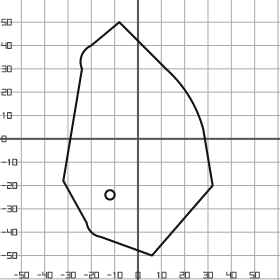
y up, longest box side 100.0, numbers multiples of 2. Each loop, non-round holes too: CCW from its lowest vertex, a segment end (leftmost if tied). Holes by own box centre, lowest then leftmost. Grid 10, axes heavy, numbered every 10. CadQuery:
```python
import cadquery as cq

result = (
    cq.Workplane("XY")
    .moveTo(6.0, -50.0)
    .lineTo(32.0, -20.0)
    .lineTo(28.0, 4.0)
    .threePointArc((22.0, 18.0), (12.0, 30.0))
    .lineTo(-8.0, 50.0)
    .lineTo(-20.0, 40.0)
    .threePointArc((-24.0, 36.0), (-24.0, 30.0))
    .lineTo(-32.0, -18.0)
    .lineTo(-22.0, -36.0)
    .threePointArc((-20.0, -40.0), (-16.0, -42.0))
    .close()
    .moveTo(-12.0, -24.0)
    .circle(2.0)
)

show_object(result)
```